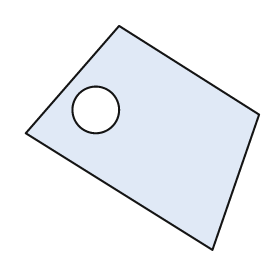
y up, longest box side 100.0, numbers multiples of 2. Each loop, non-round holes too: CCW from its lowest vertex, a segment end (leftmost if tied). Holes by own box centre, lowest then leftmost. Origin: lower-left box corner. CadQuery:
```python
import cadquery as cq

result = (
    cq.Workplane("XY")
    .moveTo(80.0, 0.0)
    .lineTo(100.0, 58.0)
    .lineTo(40.0, 96.0)
    .lineTo(0.0, 50.0)
    .close()
    .moveTo(30.0, 60.0)
    .circle(10.0)
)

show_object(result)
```